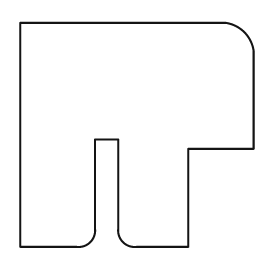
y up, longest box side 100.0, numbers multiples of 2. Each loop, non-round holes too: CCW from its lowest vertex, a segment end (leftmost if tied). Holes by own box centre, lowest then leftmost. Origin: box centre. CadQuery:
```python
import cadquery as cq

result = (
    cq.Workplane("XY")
    .moveTo(-50.0, -48.0)
    .lineTo(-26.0, -48.0)
    .threePointArc((-20.0, -46.0), (-18.0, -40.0))
    .lineTo(-18.0, -2.0)
    .lineTo(-8.0, -2.0)
    .lineTo(-8.0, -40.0)
    .threePointArc((-6.0, -46.0), (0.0, -48.0))
    .lineTo(22.0, -48.0)
    .lineTo(22.0, -6.0)
    .lineTo(50.0, -6.0)
    .lineTo(50.0, 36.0)
    .threePointArc((46.0, 44.0), (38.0, 48.0))
    .lineTo(-50.0, 48.0)
    .close()
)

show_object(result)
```